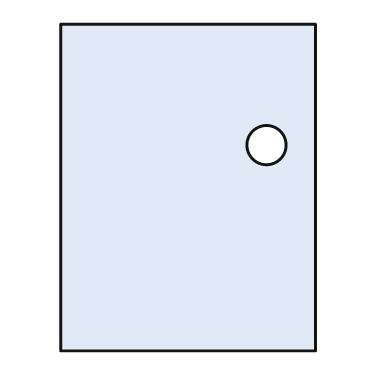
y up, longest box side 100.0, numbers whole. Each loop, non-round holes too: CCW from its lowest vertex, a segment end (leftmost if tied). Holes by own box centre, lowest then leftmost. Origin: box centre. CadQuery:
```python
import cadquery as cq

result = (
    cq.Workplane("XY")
    .moveTo(-39.0, -50.0)
    .lineTo(39.0, -50.0)
    .lineTo(39.0, 50.0)
    .lineTo(-39.0, 50.0)
    .close()
    .moveTo(24.0, 13.0)
    .circle(6.0)
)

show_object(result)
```